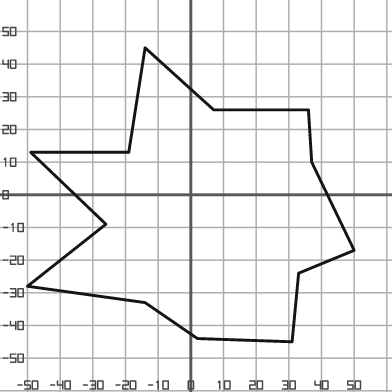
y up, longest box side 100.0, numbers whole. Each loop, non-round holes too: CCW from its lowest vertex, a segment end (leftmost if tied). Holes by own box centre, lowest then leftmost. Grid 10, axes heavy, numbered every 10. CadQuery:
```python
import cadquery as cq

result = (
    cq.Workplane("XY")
    .moveTo(31.0, -45.0)
    .lineTo(33.0, -24.0)
    .lineTo(50.0, -17.0)
    .lineTo(37.0, 10.0)
    .lineTo(36.0, 26.0)
    .lineTo(7.0, 26.0)
    .lineTo(-14.0, 45.0)
    .lineTo(-19.0, 13.0)
    .lineTo(-49.0, 13.0)
    .lineTo(-26.0, -9.0)
    .lineTo(-50.0, -28.0)
    .lineTo(-14.0, -33.0)
    .lineTo(2.0, -44.0)
    .close()
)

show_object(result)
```